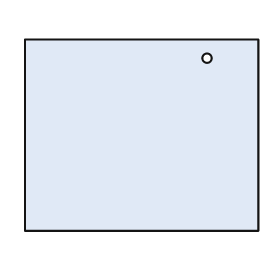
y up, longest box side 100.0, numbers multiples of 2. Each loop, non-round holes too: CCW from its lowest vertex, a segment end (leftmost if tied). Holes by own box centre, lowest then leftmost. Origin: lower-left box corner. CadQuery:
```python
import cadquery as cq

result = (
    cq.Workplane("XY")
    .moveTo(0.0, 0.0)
    .lineTo(100.0, 0.0)
    .lineTo(100.0, 82.0)
    .lineTo(0.0, 82.0)
    .close()
    .moveTo(78.0, 74.0)
    .circle(2.0)
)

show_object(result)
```